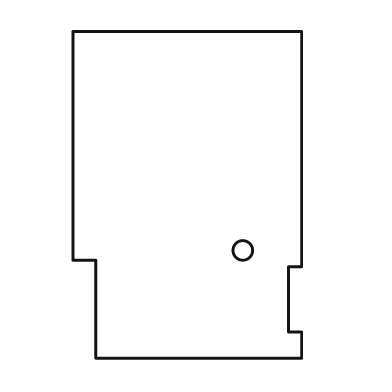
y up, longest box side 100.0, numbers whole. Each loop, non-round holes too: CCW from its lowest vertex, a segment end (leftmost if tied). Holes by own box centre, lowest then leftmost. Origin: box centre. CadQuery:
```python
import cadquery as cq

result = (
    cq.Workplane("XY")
    .moveTo(-28.0, -50.0)
    .lineTo(35.0, -50.0)
    .lineTo(35.0, -42.0)
    .lineTo(31.0, -42.0)
    .lineTo(31.0, -22.0)
    .lineTo(35.0, -22.0)
    .lineTo(35.0, 50.0)
    .lineTo(-35.0, 50.0)
    .lineTo(-35.0, -20.0)
    .lineTo(-28.0, -20.0)
    .close()
    .moveTo(17.0, -17.0)
    .circle(3.0)
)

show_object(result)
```